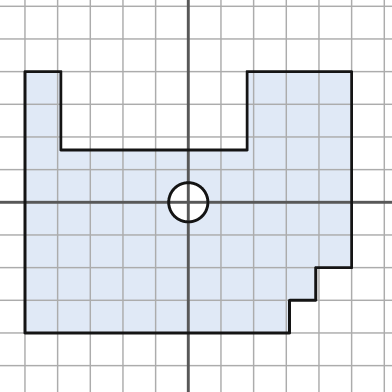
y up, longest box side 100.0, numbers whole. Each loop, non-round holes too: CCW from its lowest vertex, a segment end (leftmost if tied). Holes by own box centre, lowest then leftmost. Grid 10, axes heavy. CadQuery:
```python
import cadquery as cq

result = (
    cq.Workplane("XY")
    .moveTo(-50.0, -40.0)
    .lineTo(31.0, -40.0)
    .lineTo(31.0, -30.0)
    .lineTo(39.0, -30.0)
    .lineTo(39.0, -20.0)
    .lineTo(50.0, -20.0)
    .lineTo(50.0, 40.0)
    .lineTo(18.0, 40.0)
    .lineTo(18.0, 16.0)
    .lineTo(-39.0, 16.0)
    .lineTo(-39.0, 40.0)
    .lineTo(-50.0, 40.0)
    .close()
    .moveTo(0.0, 0.0)
    .circle(6.0)
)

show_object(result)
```